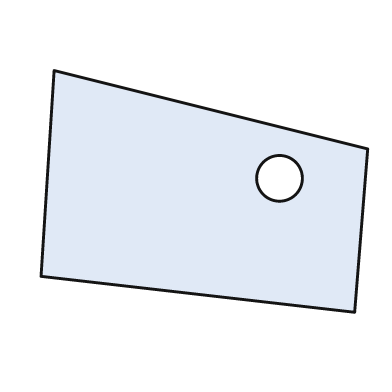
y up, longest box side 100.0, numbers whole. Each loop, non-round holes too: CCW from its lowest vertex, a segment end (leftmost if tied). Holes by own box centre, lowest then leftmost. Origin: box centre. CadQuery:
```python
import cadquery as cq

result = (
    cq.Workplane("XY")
    .moveTo(46.0, -37.0)
    .lineTo(50.0, 13.0)
    .lineTo(-46.0, 37.0)
    .lineTo(-50.0, -26.0)
    .close()
    .moveTo(23.0, 4.0)
    .circle(7.0)
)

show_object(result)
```